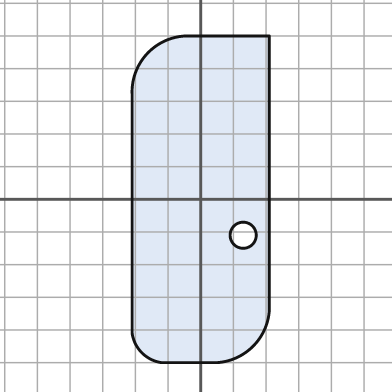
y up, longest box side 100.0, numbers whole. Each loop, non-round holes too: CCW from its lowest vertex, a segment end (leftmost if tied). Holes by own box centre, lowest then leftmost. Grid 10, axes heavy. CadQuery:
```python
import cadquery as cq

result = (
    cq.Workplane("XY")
    .moveTo(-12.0, -50.0)
    .lineTo(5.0, -50.0)
    .threePointArc((16.0, -45.0), (21.0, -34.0))
    .lineTo(21.0, 50.0)
    .lineTo(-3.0, 50.0)
    .threePointArc((-16.0, 45.0), (-21.0, 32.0))
    .lineTo(-21.0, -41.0)
    .threePointArc((-18.0, -47.0), (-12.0, -50.0))
    .close()
    .moveTo(13.0, -11.0)
    .circle(4.0)
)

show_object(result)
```